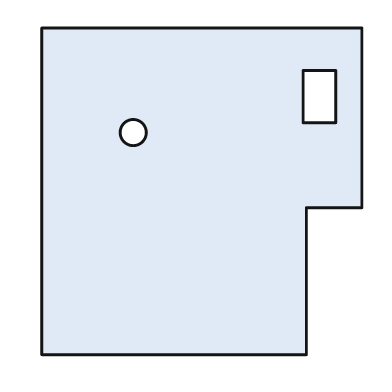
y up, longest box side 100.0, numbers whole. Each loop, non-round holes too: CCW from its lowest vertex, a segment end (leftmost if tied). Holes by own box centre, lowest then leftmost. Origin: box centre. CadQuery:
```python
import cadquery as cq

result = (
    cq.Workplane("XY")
    .moveTo(-49.0, -50.0)
    .lineTo(32.0, -50.0)
    .lineTo(32.0, -5.0)
    .lineTo(49.0, -5.0)
    .lineTo(49.0, 50.0)
    .lineTo(-49.0, 50.0)
    .close()
    .moveTo(-21.0, 18.0)
    .circle(4.0)
    .moveTo(31.0, 21.0)
    .lineTo(41.0, 21.0)
    .lineTo(41.0, 37.0)
    .lineTo(31.0, 37.0)
    .close()
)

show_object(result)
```